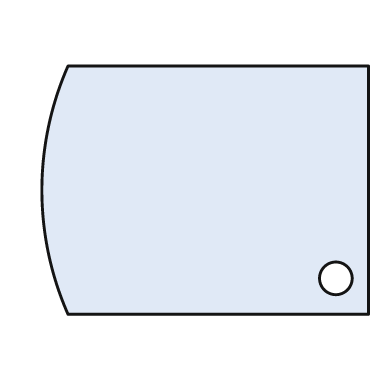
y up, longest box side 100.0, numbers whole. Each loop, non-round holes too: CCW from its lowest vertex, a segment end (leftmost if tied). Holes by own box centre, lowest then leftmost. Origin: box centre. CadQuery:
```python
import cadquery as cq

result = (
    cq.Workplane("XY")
    .moveTo(-42.0, -38.0)
    .lineTo(50.0, -38.0)
    .lineTo(50.0, 38.0)
    .lineTo(-42.0, 38.0)
    .threePointArc((-50.0, 0.0), (-42.0, -38.0))
    .close()
    .moveTo(40.0, -27.0)
    .circle(5.0)
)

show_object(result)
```